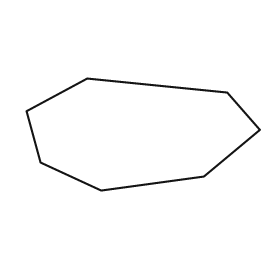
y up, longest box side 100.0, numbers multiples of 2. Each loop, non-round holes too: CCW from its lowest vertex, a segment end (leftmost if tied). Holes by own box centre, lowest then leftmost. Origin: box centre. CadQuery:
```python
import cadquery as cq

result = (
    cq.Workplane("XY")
    .moveTo(-18.0, -24.0)
    .lineTo(26.0, -18.0)
    .lineTo(50.0, 2.0)
    .lineTo(36.0, 18.0)
    .lineTo(-24.0, 24.0)
    .lineTo(-50.0, 10.0)
    .lineTo(-44.0, -12.0)
    .close()
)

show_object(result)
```